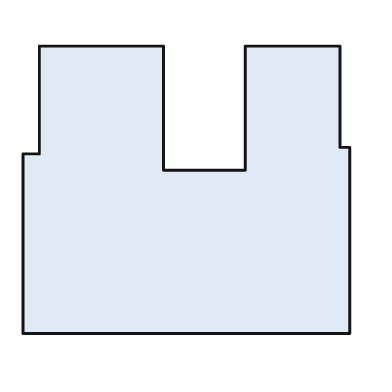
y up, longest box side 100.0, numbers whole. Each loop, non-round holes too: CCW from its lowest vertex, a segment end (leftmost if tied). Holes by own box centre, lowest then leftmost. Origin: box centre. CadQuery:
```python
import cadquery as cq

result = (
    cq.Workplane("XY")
    .moveTo(-50.0, -44.0)
    .lineTo(50.0, -44.0)
    .lineTo(50.0, 13.0)
    .lineTo(47.0, 13.0)
    .lineTo(47.0, 44.0)
    .lineTo(18.0, 44.0)
    .lineTo(18.0, 6.0)
    .lineTo(-7.0, 6.0)
    .lineTo(-7.0, 44.0)
    .lineTo(-45.0, 44.0)
    .lineTo(-45.0, 11.0)
    .lineTo(-50.0, 11.0)
    .close()
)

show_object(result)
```